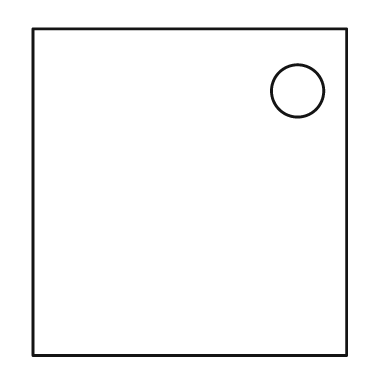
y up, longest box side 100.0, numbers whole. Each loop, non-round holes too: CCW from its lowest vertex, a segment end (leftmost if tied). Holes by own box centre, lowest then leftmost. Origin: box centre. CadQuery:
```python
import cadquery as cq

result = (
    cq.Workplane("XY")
    .moveTo(-48.0, -50.0)
    .lineTo(48.0, -50.0)
    .lineTo(48.0, 50.0)
    .lineTo(-48.0, 50.0)
    .close()
    .moveTo(33.0, 31.0)
    .circle(8.0)
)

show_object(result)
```